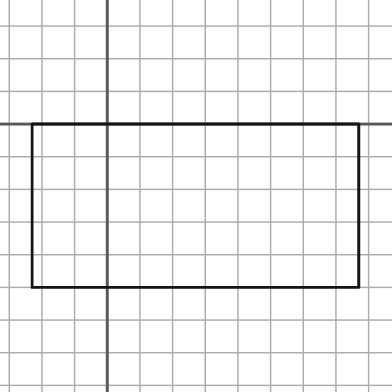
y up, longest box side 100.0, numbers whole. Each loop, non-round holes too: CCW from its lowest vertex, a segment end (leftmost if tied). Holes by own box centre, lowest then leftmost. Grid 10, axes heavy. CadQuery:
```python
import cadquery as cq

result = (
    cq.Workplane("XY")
    .moveTo(-23.0, -50.0)
    .lineTo(77.0, -50.0)
    .lineTo(77.0, 0.0)
    .lineTo(-23.0, 0.0)
    .close()
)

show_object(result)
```